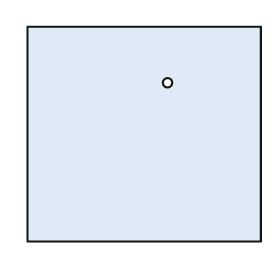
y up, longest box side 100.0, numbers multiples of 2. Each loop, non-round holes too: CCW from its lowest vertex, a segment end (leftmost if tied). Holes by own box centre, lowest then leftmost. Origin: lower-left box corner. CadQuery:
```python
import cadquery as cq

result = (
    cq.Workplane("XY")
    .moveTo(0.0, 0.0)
    .lineTo(100.0, 0.0)
    .lineTo(100.0, 92.0)
    .lineTo(0.0, 92.0)
    .close()
    .moveTo(60.0, 68.0)
    .circle(2.0)
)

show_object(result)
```